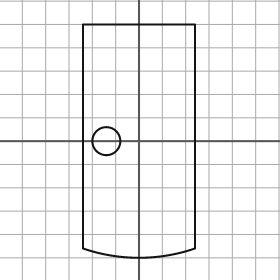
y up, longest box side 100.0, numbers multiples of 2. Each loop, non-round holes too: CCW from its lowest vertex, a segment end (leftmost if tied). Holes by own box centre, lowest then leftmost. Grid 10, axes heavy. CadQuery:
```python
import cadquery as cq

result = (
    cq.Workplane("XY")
    .moveTo(-24.0, -46.0)
    .threePointArc((0.0, -50.0), (24.0, -46.0))
    .lineTo(24.0, 50.0)
    .lineTo(-24.0, 50.0)
    .close()
    .moveTo(-14.0, 0.0)
    .circle(6.0)
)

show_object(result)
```